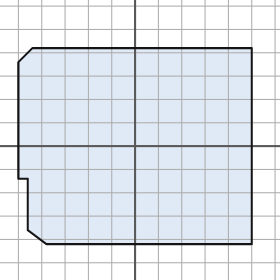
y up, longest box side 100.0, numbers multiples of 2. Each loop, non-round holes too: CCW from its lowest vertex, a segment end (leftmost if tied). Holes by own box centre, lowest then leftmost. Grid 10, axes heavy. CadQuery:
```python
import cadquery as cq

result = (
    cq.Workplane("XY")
    .moveTo(-38.0, -42.0)
    .lineTo(50.0, -42.0)
    .lineTo(50.0, 42.0)
    .lineTo(-44.0, 42.0)
    .lineTo(-50.0, 36.0)
    .lineTo(-50.0, -14.0)
    .lineTo(-46.0, -14.0)
    .lineTo(-46.0, -36.0)
    .close()
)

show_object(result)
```